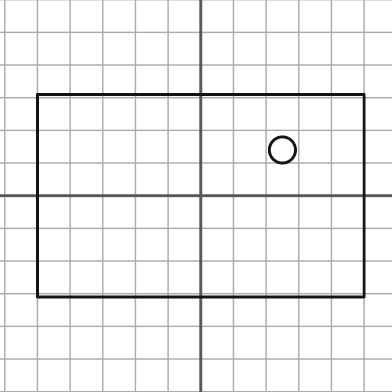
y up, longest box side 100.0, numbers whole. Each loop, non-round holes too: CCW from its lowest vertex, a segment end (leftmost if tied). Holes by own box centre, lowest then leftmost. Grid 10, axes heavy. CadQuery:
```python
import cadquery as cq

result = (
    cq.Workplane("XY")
    .moveTo(-50.0, -31.0)
    .lineTo(50.0, -31.0)
    .lineTo(50.0, 31.0)
    .lineTo(-50.0, 31.0)
    .close()
    .moveTo(25.0, 14.0)
    .circle(4.0)
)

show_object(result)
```